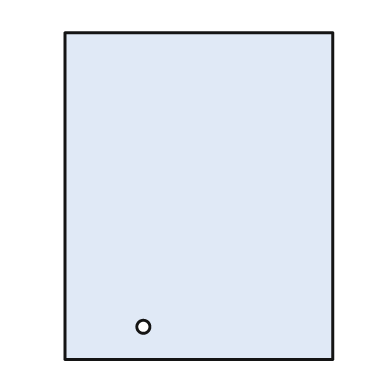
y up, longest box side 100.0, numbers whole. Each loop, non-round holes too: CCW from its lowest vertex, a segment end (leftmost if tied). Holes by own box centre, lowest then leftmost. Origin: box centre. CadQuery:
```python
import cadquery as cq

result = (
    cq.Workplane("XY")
    .moveTo(-41.0, -50.0)
    .lineTo(41.0, -50.0)
    .lineTo(41.0, 50.0)
    .lineTo(-41.0, 50.0)
    .close()
    .moveTo(-17.0, -40.0)
    .circle(2.0)
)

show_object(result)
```